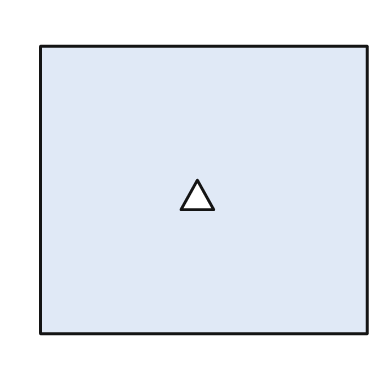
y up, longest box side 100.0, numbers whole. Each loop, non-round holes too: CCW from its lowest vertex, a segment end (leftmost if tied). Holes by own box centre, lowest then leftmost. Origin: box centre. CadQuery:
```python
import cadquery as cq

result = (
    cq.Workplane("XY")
    .moveTo(-50.0, -44.0)
    .lineTo(50.0, -44.0)
    .lineTo(50.0, 44.0)
    .lineTo(-50.0, 44.0)
    .close()
    .moveTo(-7.0, -6.0)
    .lineTo(3.0, -6.0)
    .lineTo(-2.0, 3.0)
    .close()
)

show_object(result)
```